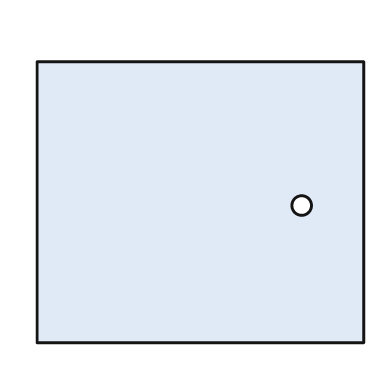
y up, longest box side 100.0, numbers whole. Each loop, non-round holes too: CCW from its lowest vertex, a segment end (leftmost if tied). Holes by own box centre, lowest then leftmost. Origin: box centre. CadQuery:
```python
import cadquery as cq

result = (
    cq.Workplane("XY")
    .moveTo(-50.0, -43.0)
    .lineTo(50.0, -43.0)
    .lineTo(50.0, 43.0)
    .lineTo(-50.0, 43.0)
    .close()
    .moveTo(31.0, -1.0)
    .circle(3.0)
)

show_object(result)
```